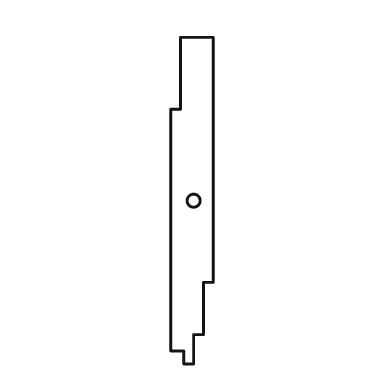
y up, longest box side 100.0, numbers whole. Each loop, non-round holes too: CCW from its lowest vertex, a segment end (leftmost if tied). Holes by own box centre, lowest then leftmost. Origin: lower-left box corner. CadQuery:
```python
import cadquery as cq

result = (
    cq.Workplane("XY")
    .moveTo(4.0, 0.0)
    .lineTo(7.0, 0.0)
    .lineTo(7.0, 9.0)
    .lineTo(10.0, 9.0)
    .lineTo(10.0, 25.0)
    .lineTo(13.0, 25.0)
    .lineTo(13.0, 100.0)
    .lineTo(3.0, 100.0)
    .lineTo(3.0, 78.0)
    .lineTo(0.0, 78.0)
    .lineTo(0.0, 4.0)
    .lineTo(4.0, 4.0)
    .close()
    .moveTo(7.0, 50.0)
    .circle(2.0)
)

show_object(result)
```